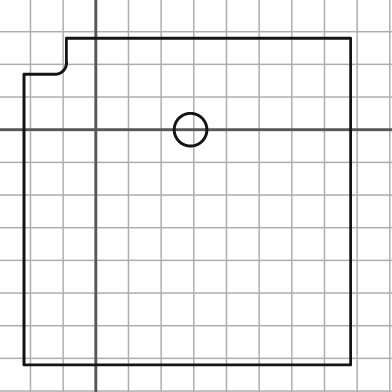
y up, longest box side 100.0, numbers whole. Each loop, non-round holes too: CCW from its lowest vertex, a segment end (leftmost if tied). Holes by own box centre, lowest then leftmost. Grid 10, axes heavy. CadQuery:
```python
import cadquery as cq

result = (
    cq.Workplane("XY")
    .moveTo(-22.0, -72.0)
    .lineTo(78.0, -72.0)
    .lineTo(78.0, 28.0)
    .lineTo(-9.0, 28.0)
    .lineTo(-9.0, 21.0)
    .threePointArc((-10.0, 18.0), (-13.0, 17.0))
    .lineTo(-22.0, 17.0)
    .close()
    .moveTo(29.0, 0.0)
    .circle(5.0)
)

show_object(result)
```